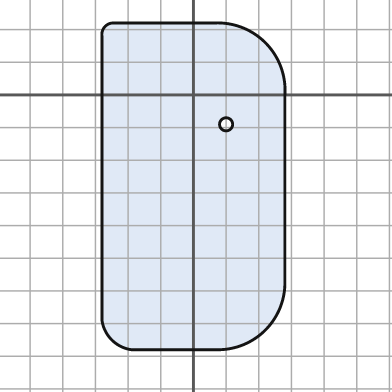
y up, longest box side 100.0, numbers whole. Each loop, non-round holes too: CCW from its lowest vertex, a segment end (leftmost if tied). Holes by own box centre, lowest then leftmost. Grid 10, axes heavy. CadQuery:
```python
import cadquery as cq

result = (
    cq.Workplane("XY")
    .moveTo(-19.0, -78.0)
    .lineTo(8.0, -78.0)
    .threePointArc((22.0, -72.0), (28.0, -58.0))
    .lineTo(28.0, 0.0)
    .threePointArc((22.0, 16.0), (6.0, 22.0))
    .lineTo(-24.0, 22.0)
    .threePointArc((-27.0, 21.0), (-28.0, 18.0))
    .lineTo(-28.0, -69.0)
    .threePointArc((-25.0, -75.0), (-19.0, -78.0))
    .close()
    .moveTo(10.0, -9.0)
    .circle(2.0)
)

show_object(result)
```